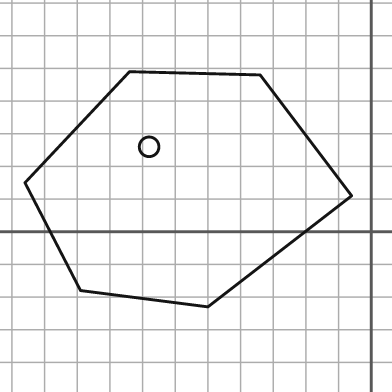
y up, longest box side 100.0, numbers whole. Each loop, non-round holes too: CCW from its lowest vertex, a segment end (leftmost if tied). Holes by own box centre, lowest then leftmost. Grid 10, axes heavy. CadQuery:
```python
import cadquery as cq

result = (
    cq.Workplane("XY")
    .moveTo(-50.0, -23.0)
    .lineTo(-6.0, 11.0)
    .lineTo(-34.0, 48.0)
    .lineTo(-74.0, 49.0)
    .lineTo(-106.0, 15.0)
    .lineTo(-89.0, -18.0)
    .close()
    .moveTo(-68.0, 26.0)
    .circle(3.0)
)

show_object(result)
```